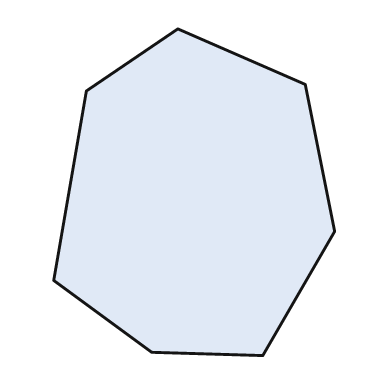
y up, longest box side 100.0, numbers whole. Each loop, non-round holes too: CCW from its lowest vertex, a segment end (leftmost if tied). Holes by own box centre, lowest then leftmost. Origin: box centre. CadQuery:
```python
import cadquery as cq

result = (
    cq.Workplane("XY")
    .moveTo(21.0, -50.0)
    .lineTo(43.0, -12.0)
    .lineTo(34.0, 33.0)
    .lineTo(-5.0, 50.0)
    .lineTo(-33.0, 31.0)
    .lineTo(-43.0, -27.0)
    .lineTo(-13.0, -49.0)
    .close()
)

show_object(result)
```